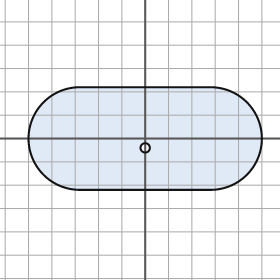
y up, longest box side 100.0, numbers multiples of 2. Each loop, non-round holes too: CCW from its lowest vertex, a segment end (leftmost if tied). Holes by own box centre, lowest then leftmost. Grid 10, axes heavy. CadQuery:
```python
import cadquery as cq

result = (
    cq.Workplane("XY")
    .moveTo(-28.0, -22.0)
    .lineTo(28.0, -22.0)
    .threePointArc((50.0, 0.0), (28.0, 22.0))
    .lineTo(-28.0, 22.0)
    .threePointArc((-50.0, 0.0), (-28.0, -22.0))
    .close()
    .moveTo(0.0, -4.0)
    .circle(2.0)
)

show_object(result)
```